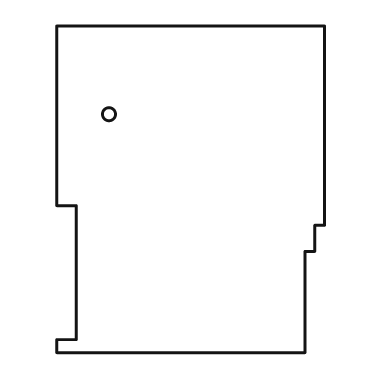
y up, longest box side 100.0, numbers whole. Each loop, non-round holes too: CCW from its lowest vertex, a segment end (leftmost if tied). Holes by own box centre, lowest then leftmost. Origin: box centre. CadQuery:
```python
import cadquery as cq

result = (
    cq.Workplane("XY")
    .moveTo(-41.0, -50.0)
    .lineTo(35.0, -50.0)
    .lineTo(35.0, -19.0)
    .lineTo(38.0, -19.0)
    .lineTo(38.0, -11.0)
    .lineTo(41.0, -11.0)
    .lineTo(41.0, 50.0)
    .lineTo(-41.0, 50.0)
    .lineTo(-41.0, -5.0)
    .lineTo(-35.0, -5.0)
    .lineTo(-35.0, -46.0)
    .lineTo(-41.0, -46.0)
    .close()
    .moveTo(-25.0, 23.0)
    .circle(2.0)
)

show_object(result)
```